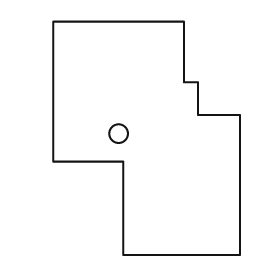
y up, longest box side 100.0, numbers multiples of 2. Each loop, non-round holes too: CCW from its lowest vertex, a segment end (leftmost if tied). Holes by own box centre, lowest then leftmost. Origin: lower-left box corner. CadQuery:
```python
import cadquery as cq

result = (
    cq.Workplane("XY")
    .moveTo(30.0, 0.0)
    .lineTo(80.0, 0.0)
    .lineTo(80.0, 60.0)
    .lineTo(62.0, 60.0)
    .lineTo(62.0, 74.0)
    .lineTo(56.0, 74.0)
    .lineTo(56.0, 100.0)
    .lineTo(0.0, 100.0)
    .lineTo(0.0, 40.0)
    .lineTo(30.0, 40.0)
    .close()
    .moveTo(28.0, 52.0)
    .circle(4.0)
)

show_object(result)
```